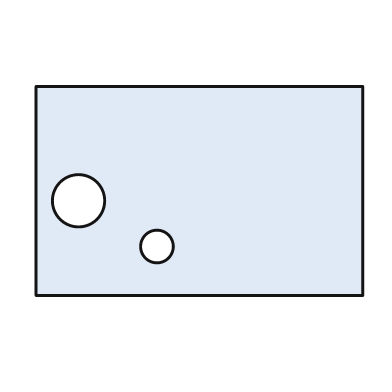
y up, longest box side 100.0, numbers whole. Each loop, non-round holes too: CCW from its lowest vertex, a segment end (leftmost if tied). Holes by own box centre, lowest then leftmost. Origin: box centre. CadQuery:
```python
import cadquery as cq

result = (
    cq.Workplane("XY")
    .moveTo(-50.0, -32.0)
    .lineTo(50.0, -32.0)
    .lineTo(50.0, 32.0)
    .lineTo(-50.0, 32.0)
    .close()
    .moveTo(-13.0, -17.0)
    .circle(5.0)
    .moveTo(-37.0, -3.0)
    .circle(8.0)
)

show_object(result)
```